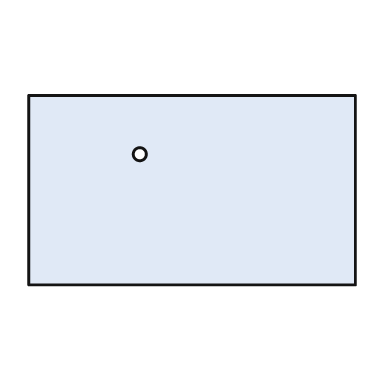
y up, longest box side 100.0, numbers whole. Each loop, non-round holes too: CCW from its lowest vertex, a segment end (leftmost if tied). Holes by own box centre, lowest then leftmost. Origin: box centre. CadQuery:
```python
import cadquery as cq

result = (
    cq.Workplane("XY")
    .moveTo(-50.0, -29.0)
    .lineTo(50.0, -29.0)
    .lineTo(50.0, 29.0)
    .lineTo(-50.0, 29.0)
    .close()
    .moveTo(-16.0, 11.0)
    .circle(2.0)
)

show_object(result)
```